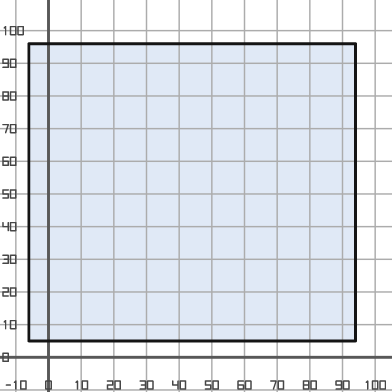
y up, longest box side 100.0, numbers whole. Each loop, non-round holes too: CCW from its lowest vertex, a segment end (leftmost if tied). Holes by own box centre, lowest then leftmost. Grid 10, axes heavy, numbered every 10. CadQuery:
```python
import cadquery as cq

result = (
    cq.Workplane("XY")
    .moveTo(-6.0, 5.0)
    .lineTo(94.0, 5.0)
    .lineTo(94.0, 96.0)
    .lineTo(-6.0, 96.0)
    .close()
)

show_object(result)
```